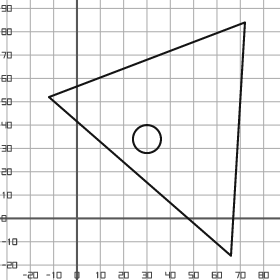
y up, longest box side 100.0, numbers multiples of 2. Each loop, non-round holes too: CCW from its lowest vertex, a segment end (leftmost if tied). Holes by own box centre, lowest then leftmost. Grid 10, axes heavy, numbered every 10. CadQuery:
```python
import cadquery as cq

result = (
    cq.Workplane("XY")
    .moveTo(66.0, -16.0)
    .lineTo(72.0, 84.0)
    .lineTo(-12.0, 52.0)
    .close()
    .moveTo(30.0, 34.0)
    .circle(6.0)
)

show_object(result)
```